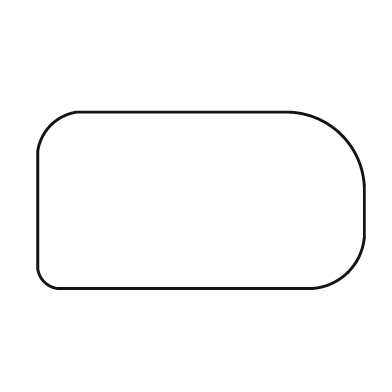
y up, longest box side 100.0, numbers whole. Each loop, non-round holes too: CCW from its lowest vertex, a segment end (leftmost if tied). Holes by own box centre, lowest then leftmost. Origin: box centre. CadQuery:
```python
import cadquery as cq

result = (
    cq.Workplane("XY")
    .moveTo(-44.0, -27.0)
    .lineTo(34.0, -27.0)
    .threePointArc((45.0, -22.0), (50.0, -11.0))
    .lineTo(50.0, 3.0)
    .threePointArc((43.0, 20.0), (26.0, 27.0))
    .lineTo(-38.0, 27.0)
    .threePointArc((-46.0, 23.0), (-50.0, 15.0))
    .lineTo(-50.0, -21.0)
    .threePointArc((-48.0, -25.0), (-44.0, -27.0))
    .close()
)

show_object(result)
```